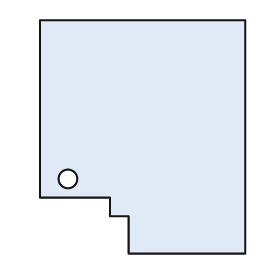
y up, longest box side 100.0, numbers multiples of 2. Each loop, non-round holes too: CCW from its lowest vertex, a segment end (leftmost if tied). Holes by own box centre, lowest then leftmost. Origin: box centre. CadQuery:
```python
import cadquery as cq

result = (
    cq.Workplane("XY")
    .moveTo(-6.0, -50.0)
    .lineTo(44.0, -50.0)
    .lineTo(44.0, 50.0)
    .lineTo(-44.0, 50.0)
    .lineTo(-44.0, -26.0)
    .lineTo(-14.0, -26.0)
    .lineTo(-14.0, -34.0)
    .lineTo(-6.0, -34.0)
    .close()
    .moveTo(-32.0, -18.0)
    .circle(4.0)
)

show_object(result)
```